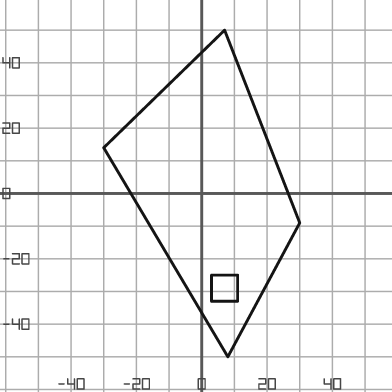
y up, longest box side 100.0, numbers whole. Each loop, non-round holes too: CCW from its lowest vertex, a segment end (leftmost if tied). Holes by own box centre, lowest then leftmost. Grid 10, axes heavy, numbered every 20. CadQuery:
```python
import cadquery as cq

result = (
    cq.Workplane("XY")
    .moveTo(8.0, -50.0)
    .lineTo(30.0, -9.0)
    .lineTo(7.0, 50.0)
    .lineTo(-30.0, 14.0)
    .close()
    .moveTo(3.0, -33.0)
    .lineTo(11.0, -33.0)
    .lineTo(11.0, -25.0)
    .lineTo(3.0, -25.0)
    .close()
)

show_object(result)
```